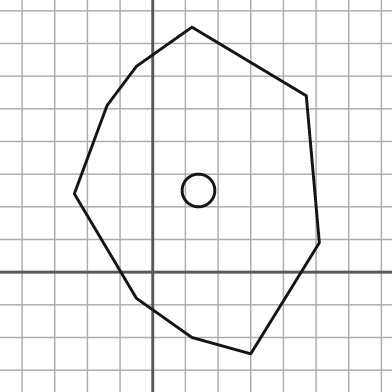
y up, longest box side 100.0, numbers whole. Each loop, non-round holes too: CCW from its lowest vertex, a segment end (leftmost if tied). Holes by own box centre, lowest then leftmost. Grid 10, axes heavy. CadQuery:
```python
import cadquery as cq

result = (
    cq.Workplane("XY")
    .moveTo(30.0, -25.0)
    .lineTo(51.0, 9.0)
    .lineTo(47.0, 54.0)
    .lineTo(12.0, 75.0)
    .lineTo(-5.0, 63.0)
    .lineTo(-14.0, 51.0)
    .lineTo(-24.0, 24.0)
    .lineTo(-5.0, -8.0)
    .lineTo(12.0, -20.0)
    .close()
    .moveTo(14.0, 25.0)
    .circle(5.0)
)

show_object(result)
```